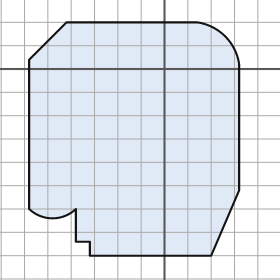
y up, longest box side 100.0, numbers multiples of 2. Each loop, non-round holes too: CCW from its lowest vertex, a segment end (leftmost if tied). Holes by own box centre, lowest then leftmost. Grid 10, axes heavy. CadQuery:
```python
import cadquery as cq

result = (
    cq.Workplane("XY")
    .moveTo(-32.0, -80.0)
    .lineTo(20.0, -80.0)
    .lineTo(32.0, -52.0)
    .lineTo(32.0, 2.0)
    .threePointArc((26.0, 14.0), (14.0, 20.0))
    .lineTo(-42.0, 20.0)
    .lineTo(-58.0, 4.0)
    .lineTo(-58.0, -60.0)
    .threePointArc((-48.0, -64.0), (-38.0, -60.0))
    .lineTo(-38.0, -74.0)
    .lineTo(-32.0, -74.0)
    .close()
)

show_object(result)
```